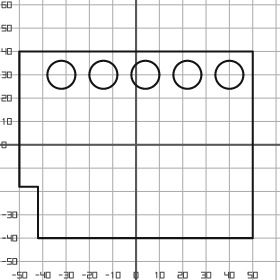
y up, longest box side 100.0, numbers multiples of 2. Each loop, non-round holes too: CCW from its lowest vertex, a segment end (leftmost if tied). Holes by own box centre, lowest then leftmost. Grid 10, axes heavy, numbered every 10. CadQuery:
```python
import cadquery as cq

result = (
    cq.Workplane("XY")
    .moveTo(-42.0, -40.0)
    .lineTo(50.0, -40.0)
    .lineTo(50.0, 40.0)
    .lineTo(-50.0, 40.0)
    .lineTo(-50.0, -18.0)
    .lineTo(-42.0, -18.0)
    .close()
    .moveTo(-32.0, 30.0)
    .circle(6.0)
    .moveTo(-14.0, 30.0)
    .circle(6.0)
    .moveTo(4.0, 30.0)
    .circle(6.0)
    .moveTo(22.0, 30.0)
    .circle(6.0)
    .moveTo(40.0, 30.0)
    .circle(6.0)
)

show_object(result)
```